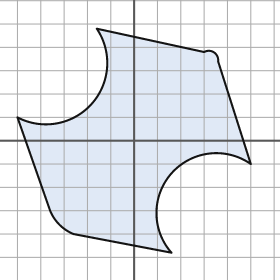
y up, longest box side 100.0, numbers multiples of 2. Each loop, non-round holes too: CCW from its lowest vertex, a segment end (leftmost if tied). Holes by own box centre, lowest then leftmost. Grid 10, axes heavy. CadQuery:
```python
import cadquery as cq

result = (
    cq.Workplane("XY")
    .moveTo(16.0, -48.0)
    .threePointArc((16.0, -14.0), (50.0, -10.0))
    .lineTo(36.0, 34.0)
    .threePointArc((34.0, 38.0), (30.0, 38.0))
    .lineTo(-16.0, 48.0)
    .threePointArc((-18.0, 16.0), (-50.0, 10.0))
    .lineTo(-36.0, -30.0)
    .threePointArc((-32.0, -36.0), (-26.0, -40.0))
    .close()
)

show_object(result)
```